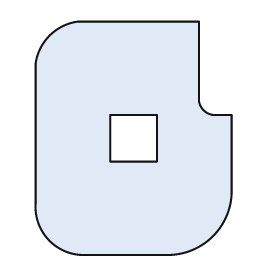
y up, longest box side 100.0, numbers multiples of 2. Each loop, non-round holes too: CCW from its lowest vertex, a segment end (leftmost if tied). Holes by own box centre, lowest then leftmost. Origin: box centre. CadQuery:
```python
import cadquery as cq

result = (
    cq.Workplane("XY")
    .moveTo(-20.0, -50.0)
    .lineTo(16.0, -50.0)
    .threePointArc((34.0, -42.0), (42.0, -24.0))
    .lineTo(42.0, 10.0)
    .lineTo(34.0, 10.0)
    .threePointArc((30.0, 12.0), (28.0, 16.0))
    .lineTo(28.0, 50.0)
    .lineTo(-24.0, 50.0)
    .threePointArc((-36.0, 44.0), (-42.0, 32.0))
    .lineTo(-42.0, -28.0)
    .threePointArc((-36.0, -44.0), (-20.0, -50.0))
    .close()
    .moveTo(-10.0, -10.0)
    .lineTo(10.0, -10.0)
    .lineTo(10.0, 10.0)
    .lineTo(-10.0, 10.0)
    .close()
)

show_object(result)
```